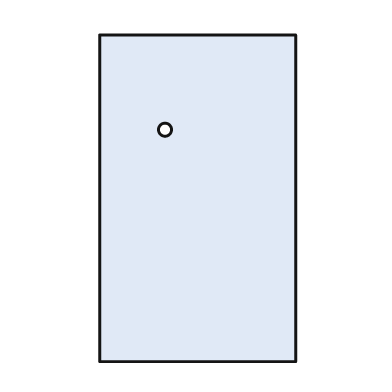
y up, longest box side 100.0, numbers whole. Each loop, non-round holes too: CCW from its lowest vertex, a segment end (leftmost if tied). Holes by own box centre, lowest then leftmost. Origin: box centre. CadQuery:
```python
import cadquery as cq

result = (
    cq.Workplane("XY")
    .moveTo(-30.0, -50.0)
    .lineTo(30.0, -50.0)
    .lineTo(30.0, 50.0)
    .lineTo(-30.0, 50.0)
    .close()
    .moveTo(-10.0, 21.0)
    .circle(2.0)
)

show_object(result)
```